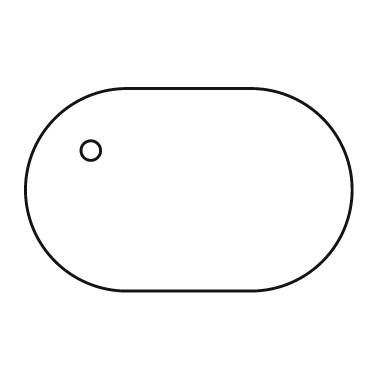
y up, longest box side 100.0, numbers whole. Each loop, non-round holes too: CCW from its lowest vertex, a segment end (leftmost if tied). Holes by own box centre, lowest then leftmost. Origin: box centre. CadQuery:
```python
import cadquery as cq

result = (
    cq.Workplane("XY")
    .moveTo(-19.0, -31.0)
    .lineTo(19.0, -31.0)
    .threePointArc((50.0, 0.0), (19.0, 31.0))
    .lineTo(-19.0, 31.0)
    .threePointArc((-50.0, 0.0), (-19.0, -31.0))
    .close()
    .moveTo(-30.0, 12.0)
    .circle(3.0)
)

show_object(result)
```